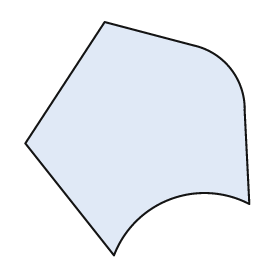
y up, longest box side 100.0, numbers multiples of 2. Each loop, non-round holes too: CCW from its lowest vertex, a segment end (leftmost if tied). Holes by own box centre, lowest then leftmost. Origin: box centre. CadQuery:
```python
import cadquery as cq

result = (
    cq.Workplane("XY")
    .moveTo(-10.0, -50.0)
    .threePointArc((14.0, -26.0), (48.0, -28.0))
    .lineTo(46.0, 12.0)
    .threePointArc((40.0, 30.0), (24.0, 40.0))
    .lineTo(-14.0, 50.0)
    .lineTo(-48.0, -2.0)
    .close()
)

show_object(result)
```